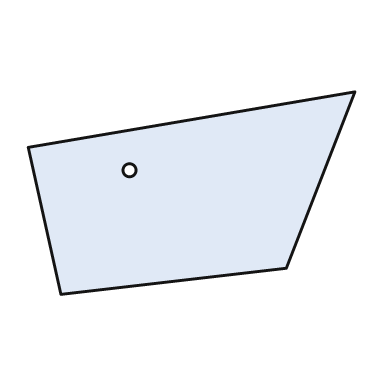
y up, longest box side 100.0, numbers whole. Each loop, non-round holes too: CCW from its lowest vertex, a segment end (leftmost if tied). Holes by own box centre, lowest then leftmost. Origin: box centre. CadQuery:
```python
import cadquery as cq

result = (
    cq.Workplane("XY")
    .moveTo(-40.0, -31.0)
    .lineTo(29.0, -23.0)
    .lineTo(50.0, 31.0)
    .lineTo(-50.0, 14.0)
    .close()
    .moveTo(-19.0, 7.0)
    .circle(2.0)
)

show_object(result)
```